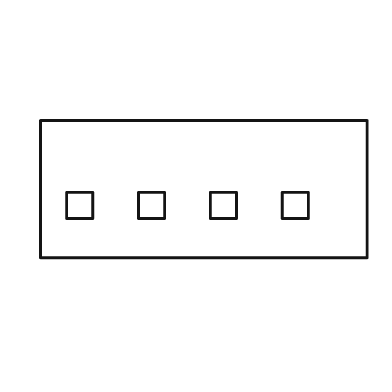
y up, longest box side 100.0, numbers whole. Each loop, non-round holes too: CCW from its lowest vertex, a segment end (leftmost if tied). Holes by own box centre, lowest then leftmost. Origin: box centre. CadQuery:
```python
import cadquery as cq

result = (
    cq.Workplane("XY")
    .moveTo(-50.0, -21.0)
    .lineTo(50.0, -21.0)
    .lineTo(50.0, 21.0)
    .lineTo(-50.0, 21.0)
    .close()
    .moveTo(-42.0, -9.0)
    .lineTo(-34.0, -9.0)
    .lineTo(-34.0, -1.0)
    .lineTo(-42.0, -1.0)
    .close()
    .moveTo(-20.0, -9.0)
    .lineTo(-12.0, -9.0)
    .lineTo(-12.0, -1.0)
    .lineTo(-20.0, -1.0)
    .close()
    .moveTo(2.0, -9.0)
    .lineTo(10.0, -9.0)
    .lineTo(10.0, -1.0)
    .lineTo(2.0, -1.0)
    .close()
    .moveTo(24.0, -9.0)
    .lineTo(32.0, -9.0)
    .lineTo(32.0, -1.0)
    .lineTo(24.0, -1.0)
    .close()
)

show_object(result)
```